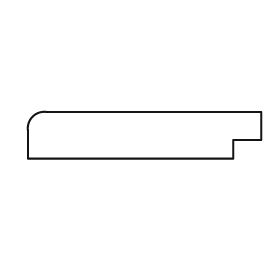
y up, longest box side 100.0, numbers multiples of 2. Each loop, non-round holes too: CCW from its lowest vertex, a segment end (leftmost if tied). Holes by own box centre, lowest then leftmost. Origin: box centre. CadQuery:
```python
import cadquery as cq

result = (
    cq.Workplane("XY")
    .moveTo(-50.0, -10.0)
    .lineTo(38.0, -10.0)
    .lineTo(38.0, -2.0)
    .lineTo(50.0, -2.0)
    .lineTo(50.0, 10.0)
    .lineTo(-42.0, 10.0)
    .threePointArc((-48.0, 8.0), (-50.0, 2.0))
    .close()
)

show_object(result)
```